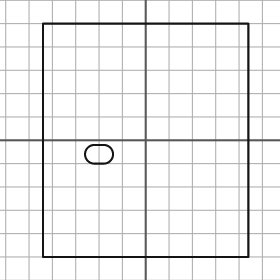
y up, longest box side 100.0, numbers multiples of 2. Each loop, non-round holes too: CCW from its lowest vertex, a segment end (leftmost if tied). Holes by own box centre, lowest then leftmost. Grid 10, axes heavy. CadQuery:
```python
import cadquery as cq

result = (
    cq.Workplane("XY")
    .moveTo(-44.0, -50.0)
    .lineTo(44.0, -50.0)
    .lineTo(44.0, 50.0)
    .lineTo(-44.0, 50.0)
    .close()
    .moveTo(-22.0, -10.0)
    .lineTo(-18.0, -10.0)
    .threePointArc((-14.0, -6.0), (-18.0, -2.0))
    .lineTo(-22.0, -2.0)
    .threePointArc((-26.0, -6.0), (-22.0, -10.0))
    .close()
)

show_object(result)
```